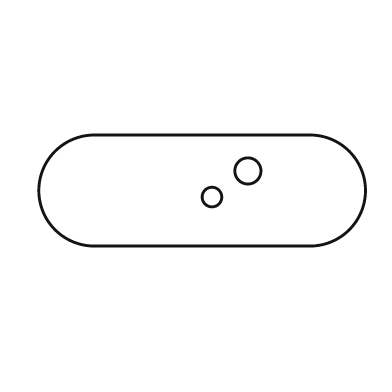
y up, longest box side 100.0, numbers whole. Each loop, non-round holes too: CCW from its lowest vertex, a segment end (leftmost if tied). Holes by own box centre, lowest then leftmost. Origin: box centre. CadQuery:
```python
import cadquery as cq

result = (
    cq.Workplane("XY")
    .moveTo(-33.0, -17.0)
    .lineTo(33.0, -17.0)
    .threePointArc((50.0, 0.0), (33.0, 17.0))
    .lineTo(-33.0, 17.0)
    .threePointArc((-50.0, 0.0), (-33.0, -17.0))
    .close()
    .moveTo(3.0, -2.0)
    .circle(3.0)
    .moveTo(14.0, 6.0)
    .circle(4.0)
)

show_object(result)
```